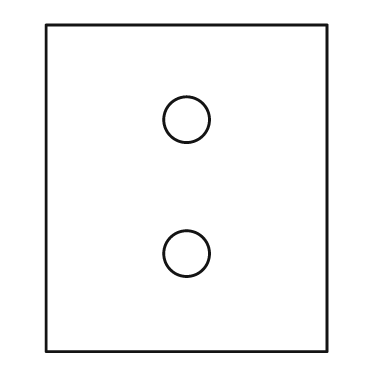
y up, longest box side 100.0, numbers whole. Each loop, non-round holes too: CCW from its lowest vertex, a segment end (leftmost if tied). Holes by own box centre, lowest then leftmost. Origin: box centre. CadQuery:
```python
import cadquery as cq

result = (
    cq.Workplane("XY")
    .moveTo(-43.0, -50.0)
    .lineTo(43.0, -50.0)
    .lineTo(43.0, 50.0)
    .lineTo(-43.0, 50.0)
    .close()
    .moveTo(0.0, -20.0)
    .circle(7.0)
    .moveTo(0.0, 21.0)
    .circle(7.0)
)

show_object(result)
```